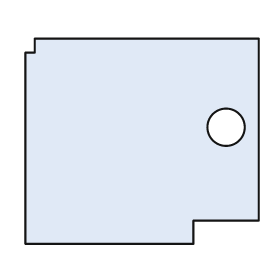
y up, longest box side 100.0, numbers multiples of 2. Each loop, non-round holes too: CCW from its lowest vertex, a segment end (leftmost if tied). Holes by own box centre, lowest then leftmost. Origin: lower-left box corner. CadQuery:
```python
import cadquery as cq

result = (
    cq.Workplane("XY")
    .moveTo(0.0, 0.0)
    .lineTo(72.0, 0.0)
    .lineTo(72.0, 10.0)
    .lineTo(100.0, 10.0)
    .lineTo(100.0, 88.0)
    .lineTo(4.0, 88.0)
    .lineTo(4.0, 82.0)
    .lineTo(0.0, 82.0)
    .close()
    .moveTo(86.0, 50.0)
    .circle(8.0)
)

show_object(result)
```